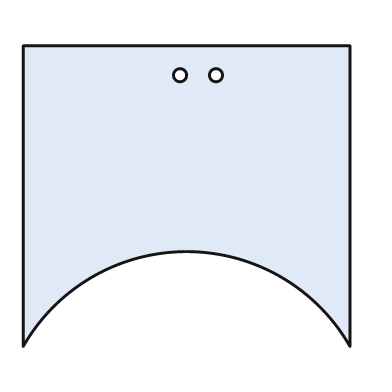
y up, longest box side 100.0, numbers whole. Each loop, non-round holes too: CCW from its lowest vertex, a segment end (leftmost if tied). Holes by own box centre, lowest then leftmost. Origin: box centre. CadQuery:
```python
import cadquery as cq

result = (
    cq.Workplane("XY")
    .moveTo(-50.0, -46.0)
    .threePointArc((0.0, -17.0), (50.0, -46.0))
    .lineTo(50.0, 46.0)
    .lineTo(-50.0, 46.0)
    .close()
    .moveTo(-2.0, 37.0)
    .circle(2.0)
    .moveTo(9.0, 37.0)
    .circle(2.0)
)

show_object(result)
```